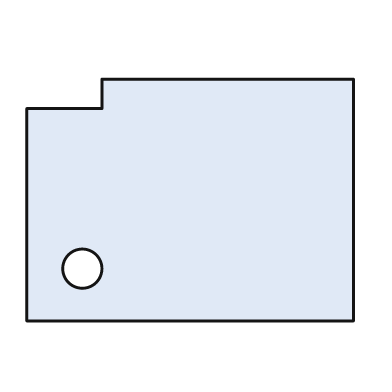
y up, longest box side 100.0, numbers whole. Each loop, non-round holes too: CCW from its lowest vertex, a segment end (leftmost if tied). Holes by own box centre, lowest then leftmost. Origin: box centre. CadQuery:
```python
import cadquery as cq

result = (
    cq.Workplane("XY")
    .moveTo(-50.0, -37.0)
    .lineTo(50.0, -37.0)
    .lineTo(50.0, 37.0)
    .lineTo(-27.0, 37.0)
    .lineTo(-27.0, 28.0)
    .lineTo(-50.0, 28.0)
    .close()
    .moveTo(-33.0, -21.0)
    .circle(6.0)
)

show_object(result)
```